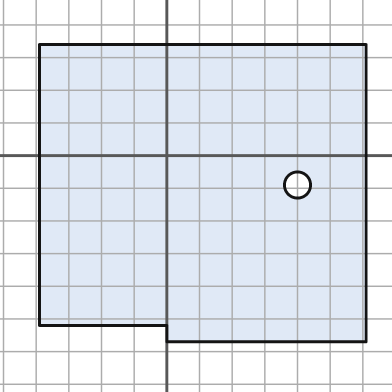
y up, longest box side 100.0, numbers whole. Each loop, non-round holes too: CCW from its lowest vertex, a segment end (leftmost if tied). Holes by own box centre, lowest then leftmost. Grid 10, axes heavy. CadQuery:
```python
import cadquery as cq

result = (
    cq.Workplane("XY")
    .moveTo(0.0, -57.0)
    .lineTo(61.0, -57.0)
    .lineTo(61.0, 34.0)
    .lineTo(-39.0, 34.0)
    .lineTo(-39.0, -52.0)
    .lineTo(0.0, -52.0)
    .close()
    .moveTo(40.0, -9.0)
    .circle(4.0)
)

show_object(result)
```